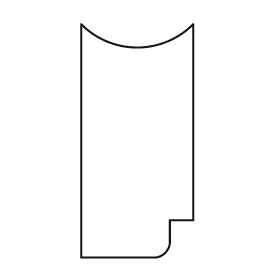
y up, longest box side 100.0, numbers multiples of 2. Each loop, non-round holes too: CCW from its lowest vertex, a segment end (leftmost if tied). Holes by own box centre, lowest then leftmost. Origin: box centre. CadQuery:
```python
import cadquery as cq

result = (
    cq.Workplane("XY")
    .moveTo(-24.0, -50.0)
    .lineTo(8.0, -50.0)
    .threePointArc((12.0, -48.0), (14.0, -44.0))
    .lineTo(14.0, -34.0)
    .lineTo(24.0, -34.0)
    .lineTo(24.0, 50.0)
    .threePointArc((0.0, 40.0), (-24.0, 50.0))
    .close()
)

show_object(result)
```